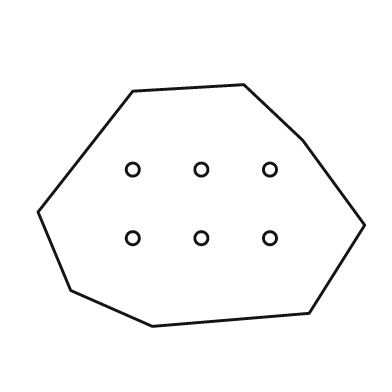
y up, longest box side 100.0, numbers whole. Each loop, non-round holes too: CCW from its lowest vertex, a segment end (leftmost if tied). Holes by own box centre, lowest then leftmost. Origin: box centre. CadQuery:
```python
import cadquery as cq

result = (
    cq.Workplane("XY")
    .moveTo(-15.0, -37.0)
    .lineTo(33.0, -33.0)
    .lineTo(50.0, -6.0)
    .lineTo(31.0, 20.0)
    .lineTo(13.0, 37.0)
    .lineTo(-21.0, 35.0)
    .lineTo(-50.0, -2.0)
    .lineTo(-40.0, -26.0)
    .close()
    .moveTo(-21.0, -10.0)
    .circle(2.0)
    .moveTo(0.0, -10.0)
    .circle(2.0)
    .moveTo(21.0, -10.0)
    .circle(2.0)
    .moveTo(-21.0, 11.0)
    .circle(2.0)
    .moveTo(0.0, 11.0)
    .circle(2.0)
    .moveTo(21.0, 11.0)
    .circle(2.0)
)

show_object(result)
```